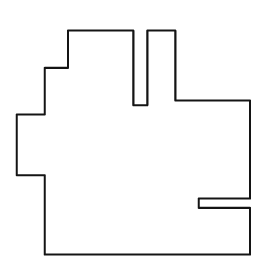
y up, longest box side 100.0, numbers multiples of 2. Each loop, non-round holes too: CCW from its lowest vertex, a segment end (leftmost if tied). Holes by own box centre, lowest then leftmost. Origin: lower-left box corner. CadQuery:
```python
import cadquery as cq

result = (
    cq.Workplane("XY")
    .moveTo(12.0, 0.0)
    .lineTo(100.0, 0.0)
    .lineTo(100.0, 20.0)
    .lineTo(78.0, 20.0)
    .lineTo(78.0, 24.0)
    .lineTo(100.0, 24.0)
    .lineTo(100.0, 66.0)
    .lineTo(68.0, 66.0)
    .lineTo(68.0, 96.0)
    .lineTo(56.0, 96.0)
    .lineTo(56.0, 64.0)
    .lineTo(50.0, 64.0)
    .lineTo(50.0, 96.0)
    .lineTo(22.0, 96.0)
    .lineTo(22.0, 80.0)
    .lineTo(12.0, 80.0)
    .lineTo(12.0, 60.0)
    .lineTo(0.0, 60.0)
    .lineTo(0.0, 34.0)
    .lineTo(12.0, 34.0)
    .close()
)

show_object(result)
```